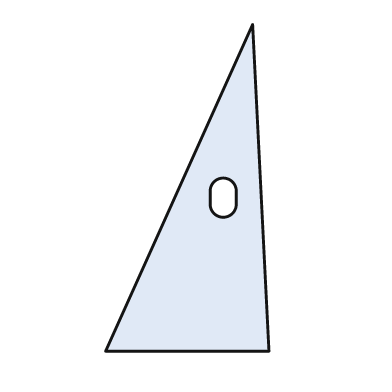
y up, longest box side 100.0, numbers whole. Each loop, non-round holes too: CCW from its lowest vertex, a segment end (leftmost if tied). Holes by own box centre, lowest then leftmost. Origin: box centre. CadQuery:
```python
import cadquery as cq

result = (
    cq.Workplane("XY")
    .moveTo(-25.0, -50.0)
    .lineTo(25.0, -50.0)
    .lineTo(20.0, 50.0)
    .close()
    .moveTo(7.0, -5.0)
    .threePointArc((11.0, -9.0), (15.0, -5.0))
    .lineTo(15.0, -1.0)
    .threePointArc((11.0, 3.0), (7.0, -1.0))
    .close()
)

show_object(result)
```